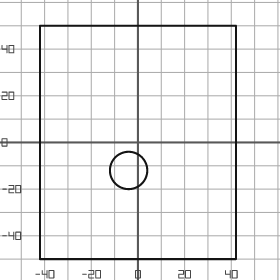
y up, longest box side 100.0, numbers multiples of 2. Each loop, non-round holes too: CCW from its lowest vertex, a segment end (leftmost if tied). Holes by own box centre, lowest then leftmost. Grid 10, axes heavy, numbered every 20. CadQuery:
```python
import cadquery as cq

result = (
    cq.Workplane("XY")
    .moveTo(-42.0, -50.0)
    .lineTo(42.0, -50.0)
    .lineTo(42.0, 50.0)
    .lineTo(-42.0, 50.0)
    .close()
    .moveTo(-4.0, -12.0)
    .circle(8.0)
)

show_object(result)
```